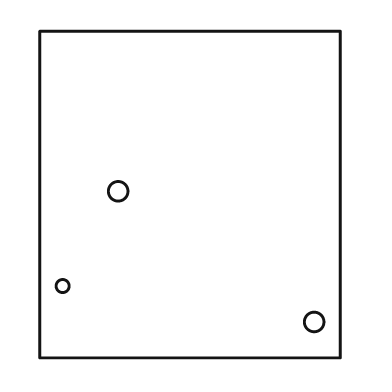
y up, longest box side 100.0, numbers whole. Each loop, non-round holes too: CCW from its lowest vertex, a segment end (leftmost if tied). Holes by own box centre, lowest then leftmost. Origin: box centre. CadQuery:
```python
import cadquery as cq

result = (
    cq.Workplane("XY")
    .moveTo(-46.0, -50.0)
    .lineTo(46.0, -50.0)
    .lineTo(46.0, 50.0)
    .lineTo(-46.0, 50.0)
    .close()
    .moveTo(38.0, -39.0)
    .circle(3.0)
    .moveTo(-39.0, -28.0)
    .circle(2.0)
    .moveTo(-22.0, 1.0)
    .circle(3.0)
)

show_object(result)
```